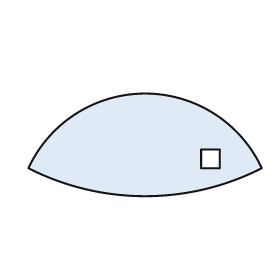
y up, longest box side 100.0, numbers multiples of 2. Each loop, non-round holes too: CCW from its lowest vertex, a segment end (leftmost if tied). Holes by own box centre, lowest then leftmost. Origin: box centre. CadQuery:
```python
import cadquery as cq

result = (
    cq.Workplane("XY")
    .moveTo(-50.0, -10.0)
    .threePointArc((0.0, -22.0), (50.0, -10.0))
    .threePointArc((0.0, 22.0), (-50.0, -10.0))
    .close()
    .moveTo(24.0, -10.0)
    .lineTo(32.0, -10.0)
    .lineTo(32.0, -2.0)
    .lineTo(24.0, -2.0)
    .close()
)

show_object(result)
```